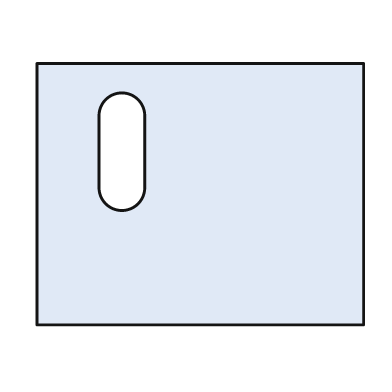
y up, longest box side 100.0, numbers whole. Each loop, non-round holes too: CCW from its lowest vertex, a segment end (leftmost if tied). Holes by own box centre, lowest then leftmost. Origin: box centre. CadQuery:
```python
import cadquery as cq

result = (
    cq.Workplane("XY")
    .moveTo(-50.0, -40.0)
    .lineTo(50.0, -40.0)
    .lineTo(50.0, 40.0)
    .lineTo(-50.0, 40.0)
    .close()
    .moveTo(-31.0, 2.0)
    .threePointArc((-24.0, -5.0), (-17.0, 2.0))
    .lineTo(-17.0, 24.0)
    .threePointArc((-24.0, 31.0), (-31.0, 24.0))
    .close()
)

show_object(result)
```